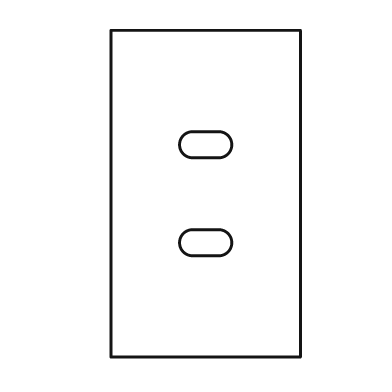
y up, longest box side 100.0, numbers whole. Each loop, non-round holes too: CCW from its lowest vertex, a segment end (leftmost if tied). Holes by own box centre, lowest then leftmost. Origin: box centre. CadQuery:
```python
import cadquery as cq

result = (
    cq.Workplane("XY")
    .moveTo(-29.0, -50.0)
    .lineTo(29.0, -50.0)
    .lineTo(29.0, 50.0)
    .lineTo(-29.0, 50.0)
    .close()
    .moveTo(-4.0, -19.0)
    .lineTo(4.0, -19.0)
    .threePointArc((8.0, -15.0), (4.0, -11.0))
    .lineTo(-4.0, -11.0)
    .threePointArc((-8.0, -15.0), (-4.0, -19.0))
    .close()
    .moveTo(-4.0, 11.0)
    .lineTo(4.0, 11.0)
    .threePointArc((8.0, 15.0), (4.0, 19.0))
    .lineTo(-4.0, 19.0)
    .threePointArc((-8.0, 15.0), (-4.0, 11.0))
    .close()
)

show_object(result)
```